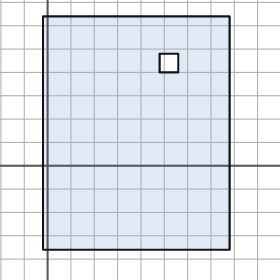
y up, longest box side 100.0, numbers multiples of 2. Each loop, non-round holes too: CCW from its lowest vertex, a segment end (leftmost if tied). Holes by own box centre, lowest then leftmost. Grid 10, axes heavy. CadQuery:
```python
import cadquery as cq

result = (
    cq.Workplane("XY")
    .moveTo(-2.0, -36.0)
    .lineTo(78.0, -36.0)
    .lineTo(78.0, 64.0)
    .lineTo(-2.0, 64.0)
    .close()
    .moveTo(48.0, 40.0)
    .lineTo(56.0, 40.0)
    .lineTo(56.0, 48.0)
    .lineTo(48.0, 48.0)
    .close()
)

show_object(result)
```